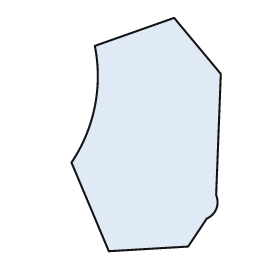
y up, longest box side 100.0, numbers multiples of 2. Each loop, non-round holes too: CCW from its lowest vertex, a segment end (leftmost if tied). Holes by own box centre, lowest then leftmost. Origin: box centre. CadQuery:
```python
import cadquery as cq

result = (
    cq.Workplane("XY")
    .moveTo(-16.0, -50.0)
    .lineTo(18.0, -48.0)
    .lineTo(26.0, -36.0)
    .threePointArc((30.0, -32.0), (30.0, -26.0))
    .lineTo(32.0, 26.0)
    .lineTo(12.0, 50.0)
    .lineTo(-22.0, 38.0)
    .threePointArc((-22.0, 12.0), (-32.0, -12.0))
    .close()
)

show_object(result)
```